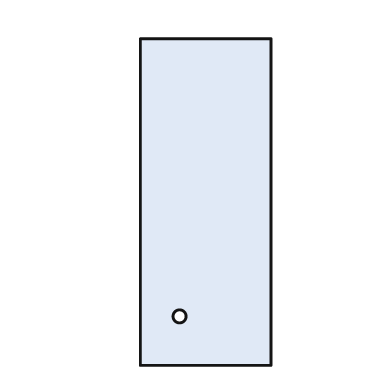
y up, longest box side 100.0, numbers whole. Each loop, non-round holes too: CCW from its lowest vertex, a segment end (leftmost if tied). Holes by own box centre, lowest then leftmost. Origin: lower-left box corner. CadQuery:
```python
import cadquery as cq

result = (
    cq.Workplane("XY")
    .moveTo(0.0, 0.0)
    .lineTo(40.0, 0.0)
    .lineTo(40.0, 100.0)
    .lineTo(0.0, 100.0)
    .close()
    .moveTo(12.0, 15.0)
    .circle(2.0)
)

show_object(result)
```